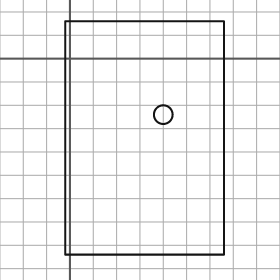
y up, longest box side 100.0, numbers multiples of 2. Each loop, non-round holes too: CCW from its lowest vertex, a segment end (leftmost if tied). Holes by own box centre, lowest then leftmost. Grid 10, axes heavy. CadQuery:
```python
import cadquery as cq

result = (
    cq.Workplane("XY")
    .moveTo(-2.0, -84.0)
    .lineTo(66.0, -84.0)
    .lineTo(66.0, 16.0)
    .lineTo(-2.0, 16.0)
    .close()
    .moveTo(40.0, -24.0)
    .circle(4.0)
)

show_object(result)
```